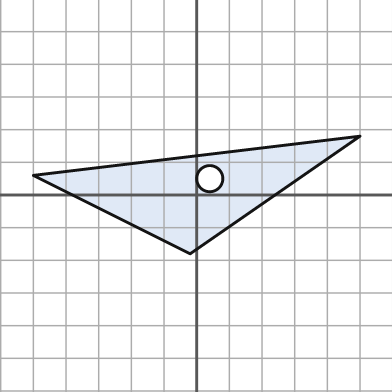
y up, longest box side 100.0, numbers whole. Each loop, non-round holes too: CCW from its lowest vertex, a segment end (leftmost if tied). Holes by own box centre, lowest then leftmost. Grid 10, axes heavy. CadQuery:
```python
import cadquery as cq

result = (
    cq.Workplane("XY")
    .moveTo(-2.0, -18.0)
    .lineTo(50.0, 18.0)
    .lineTo(-50.0, 6.0)
    .close()
    .moveTo(4.0, 5.0)
    .circle(4.0)
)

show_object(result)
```